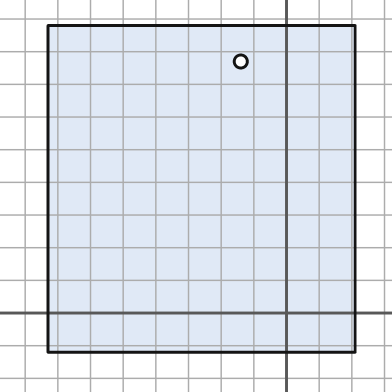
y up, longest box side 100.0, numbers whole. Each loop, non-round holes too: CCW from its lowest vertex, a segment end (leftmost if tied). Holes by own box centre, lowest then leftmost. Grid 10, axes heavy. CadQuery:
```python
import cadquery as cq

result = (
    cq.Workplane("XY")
    .moveTo(-73.0, -12.0)
    .lineTo(21.0, -12.0)
    .lineTo(21.0, 88.0)
    .lineTo(-73.0, 88.0)
    .close()
    .moveTo(-14.0, 77.0)
    .circle(2.0)
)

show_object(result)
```